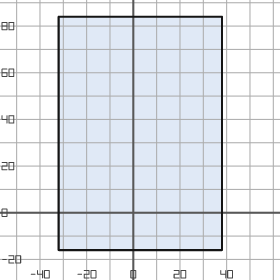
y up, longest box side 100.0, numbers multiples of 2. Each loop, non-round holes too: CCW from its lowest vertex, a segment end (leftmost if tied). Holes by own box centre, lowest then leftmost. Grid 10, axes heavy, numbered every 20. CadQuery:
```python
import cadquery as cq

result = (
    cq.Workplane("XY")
    .moveTo(-32.0, -16.0)
    .lineTo(38.0, -16.0)
    .lineTo(38.0, 84.0)
    .lineTo(-32.0, 84.0)
    .close()
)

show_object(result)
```